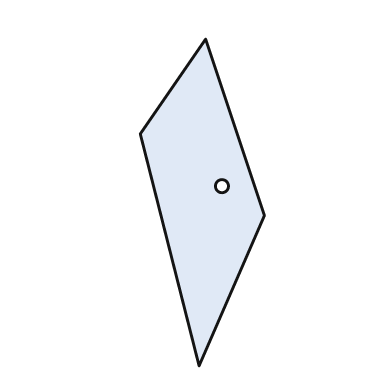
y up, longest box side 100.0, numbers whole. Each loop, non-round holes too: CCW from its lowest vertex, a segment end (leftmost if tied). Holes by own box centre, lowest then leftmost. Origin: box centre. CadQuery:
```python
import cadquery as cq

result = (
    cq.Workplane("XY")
    .moveTo(-1.0, -50.0)
    .lineTo(19.0, -4.0)
    .lineTo(1.0, 50.0)
    .lineTo(-19.0, 21.0)
    .close()
    .moveTo(6.0, 5.0)
    .circle(2.0)
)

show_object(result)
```